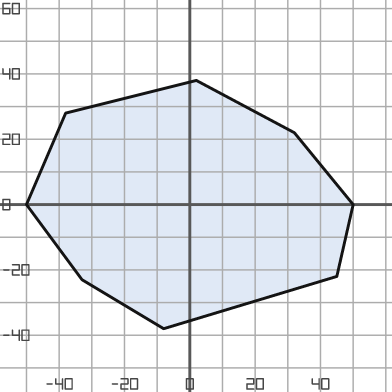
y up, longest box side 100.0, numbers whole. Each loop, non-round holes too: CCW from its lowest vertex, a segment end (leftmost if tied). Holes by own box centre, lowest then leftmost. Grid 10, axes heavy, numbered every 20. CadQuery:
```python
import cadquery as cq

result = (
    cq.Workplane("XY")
    .moveTo(-8.0, -38.0)
    .lineTo(45.0, -22.0)
    .lineTo(50.0, 0.0)
    .lineTo(32.0, 22.0)
    .lineTo(2.0, 38.0)
    .lineTo(-38.0, 28.0)
    .lineTo(-50.0, 0.0)
    .lineTo(-33.0, -23.0)
    .close()
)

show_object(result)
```